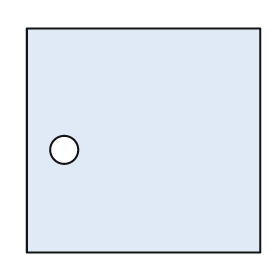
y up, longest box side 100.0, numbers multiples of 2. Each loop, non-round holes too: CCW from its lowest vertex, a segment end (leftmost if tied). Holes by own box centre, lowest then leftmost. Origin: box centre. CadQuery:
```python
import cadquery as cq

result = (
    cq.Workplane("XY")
    .moveTo(-50.0, -48.0)
    .lineTo(50.0, -48.0)
    .lineTo(50.0, 48.0)
    .lineTo(-50.0, 48.0)
    .close()
    .moveTo(-34.0, -4.0)
    .circle(6.0)
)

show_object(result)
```